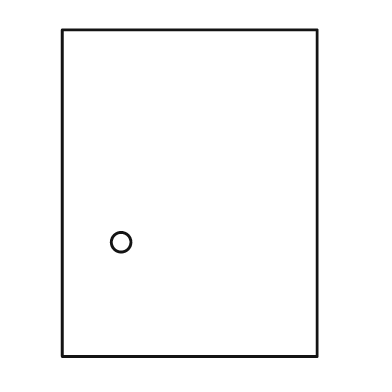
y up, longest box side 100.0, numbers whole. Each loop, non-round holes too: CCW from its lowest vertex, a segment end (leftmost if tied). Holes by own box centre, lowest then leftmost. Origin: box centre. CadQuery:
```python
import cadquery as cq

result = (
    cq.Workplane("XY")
    .moveTo(-39.0, -50.0)
    .lineTo(39.0, -50.0)
    .lineTo(39.0, 50.0)
    .lineTo(-39.0, 50.0)
    .close()
    .moveTo(-21.0, -15.0)
    .circle(3.0)
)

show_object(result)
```